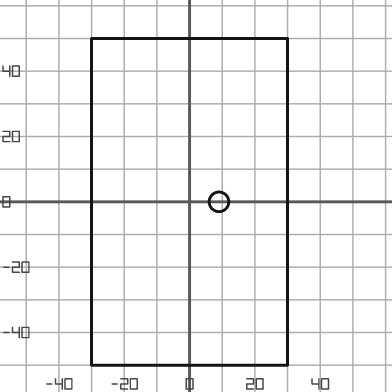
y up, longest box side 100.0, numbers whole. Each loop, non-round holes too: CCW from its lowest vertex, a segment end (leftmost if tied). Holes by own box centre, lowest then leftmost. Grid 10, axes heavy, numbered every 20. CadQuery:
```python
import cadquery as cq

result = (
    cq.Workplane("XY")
    .moveTo(-30.0, -50.0)
    .lineTo(30.0, -50.0)
    .lineTo(30.0, 50.0)
    .lineTo(-30.0, 50.0)
    .close()
    .moveTo(9.0, 0.0)
    .circle(3.0)
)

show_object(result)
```